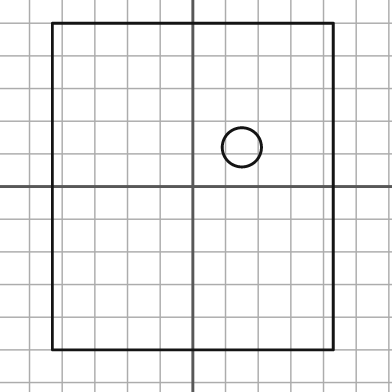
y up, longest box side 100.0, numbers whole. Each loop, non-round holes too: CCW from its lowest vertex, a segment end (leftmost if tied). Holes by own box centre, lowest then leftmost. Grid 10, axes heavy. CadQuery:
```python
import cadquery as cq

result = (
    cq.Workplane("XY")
    .moveTo(-43.0, -50.0)
    .lineTo(43.0, -50.0)
    .lineTo(43.0, 50.0)
    .lineTo(-43.0, 50.0)
    .close()
    .moveTo(15.0, 12.0)
    .circle(6.0)
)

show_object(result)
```